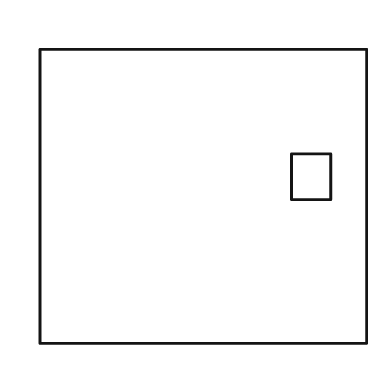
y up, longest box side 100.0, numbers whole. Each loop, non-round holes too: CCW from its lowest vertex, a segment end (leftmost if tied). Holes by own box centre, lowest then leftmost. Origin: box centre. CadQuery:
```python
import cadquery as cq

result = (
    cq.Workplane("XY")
    .moveTo(-50.0, -45.0)
    .lineTo(50.0, -45.0)
    .lineTo(50.0, 45.0)
    .lineTo(-50.0, 45.0)
    .close()
    .moveTo(27.0, -1.0)
    .lineTo(39.0, -1.0)
    .lineTo(39.0, 13.0)
    .lineTo(27.0, 13.0)
    .close()
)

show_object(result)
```